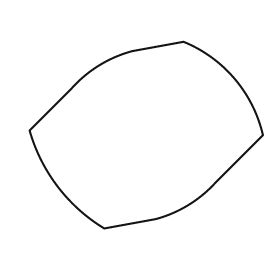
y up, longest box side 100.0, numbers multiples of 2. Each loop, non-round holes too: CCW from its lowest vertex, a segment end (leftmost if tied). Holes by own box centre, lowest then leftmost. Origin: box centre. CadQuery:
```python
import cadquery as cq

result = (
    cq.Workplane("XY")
    .moveTo(-18.0, -40.0)
    .lineTo(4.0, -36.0)
    .threePointArc((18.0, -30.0), (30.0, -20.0))
    .lineTo(50.0, 0.0)
    .threePointArc((38.0, 24.0), (16.0, 40.0))
    .lineTo(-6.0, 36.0)
    .threePointArc((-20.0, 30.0), (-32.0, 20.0))
    .lineTo(-50.0, 2.0)
    .threePointArc((-38.0, -22.0), (-18.0, -40.0))
    .close()
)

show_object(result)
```